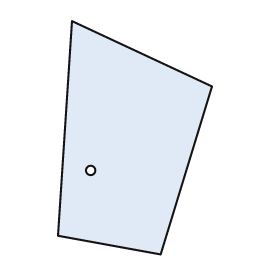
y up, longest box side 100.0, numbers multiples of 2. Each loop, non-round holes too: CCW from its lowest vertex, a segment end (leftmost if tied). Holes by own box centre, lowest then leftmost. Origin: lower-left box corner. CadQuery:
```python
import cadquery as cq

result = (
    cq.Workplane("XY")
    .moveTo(44.0, 0.0)
    .lineTo(66.0, 72.0)
    .lineTo(6.0, 100.0)
    .lineTo(0.0, 8.0)
    .close()
    .moveTo(14.0, 36.0)
    .circle(2.0)
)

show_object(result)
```